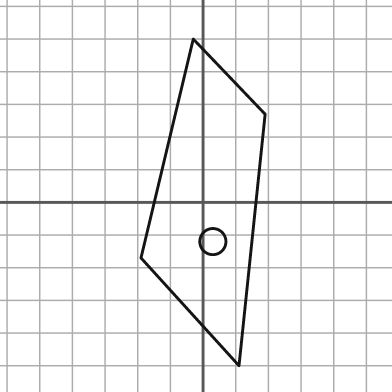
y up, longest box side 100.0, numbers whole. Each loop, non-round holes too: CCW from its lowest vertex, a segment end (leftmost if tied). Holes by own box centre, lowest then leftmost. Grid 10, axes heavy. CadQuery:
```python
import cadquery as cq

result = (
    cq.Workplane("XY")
    .moveTo(11.0, -50.0)
    .lineTo(19.0, 27.0)
    .lineTo(-3.0, 50.0)
    .lineTo(-19.0, -17.0)
    .close()
    .moveTo(3.0, -12.0)
    .circle(4.0)
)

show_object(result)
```